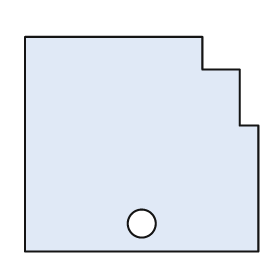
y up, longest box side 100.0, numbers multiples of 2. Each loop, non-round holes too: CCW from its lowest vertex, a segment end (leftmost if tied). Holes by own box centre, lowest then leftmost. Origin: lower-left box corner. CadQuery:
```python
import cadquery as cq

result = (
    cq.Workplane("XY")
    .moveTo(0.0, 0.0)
    .lineTo(100.0, 0.0)
    .lineTo(100.0, 54.0)
    .lineTo(92.0, 54.0)
    .lineTo(92.0, 78.0)
    .lineTo(76.0, 78.0)
    .lineTo(76.0, 92.0)
    .lineTo(0.0, 92.0)
    .close()
    .moveTo(50.0, 12.0)
    .circle(6.0)
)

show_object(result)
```